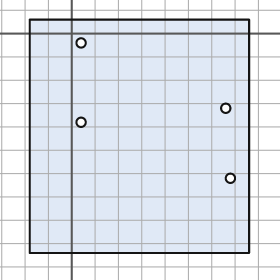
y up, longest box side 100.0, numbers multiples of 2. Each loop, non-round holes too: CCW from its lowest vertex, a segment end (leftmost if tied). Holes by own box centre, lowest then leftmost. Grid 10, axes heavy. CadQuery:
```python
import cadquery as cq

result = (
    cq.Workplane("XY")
    .moveTo(-18.0, -94.0)
    .lineTo(76.0, -94.0)
    .lineTo(76.0, 6.0)
    .lineTo(-18.0, 6.0)
    .close()
    .moveTo(68.0, -62.0)
    .circle(2.0)
    .moveTo(4.0, -38.0)
    .circle(2.0)
    .moveTo(66.0, -32.0)
    .circle(2.0)
    .moveTo(4.0, -4.0)
    .circle(2.0)
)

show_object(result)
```